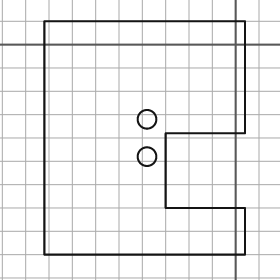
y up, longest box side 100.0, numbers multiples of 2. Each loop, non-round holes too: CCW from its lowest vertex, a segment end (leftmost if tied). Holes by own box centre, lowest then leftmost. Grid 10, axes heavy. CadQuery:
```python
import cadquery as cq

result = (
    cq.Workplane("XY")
    .moveTo(-82.0, -90.0)
    .lineTo(4.0, -90.0)
    .lineTo(4.0, -70.0)
    .lineTo(-30.0, -70.0)
    .lineTo(-30.0, -38.0)
    .lineTo(4.0, -38.0)
    .lineTo(4.0, 10.0)
    .lineTo(-82.0, 10.0)
    .close()
    .moveTo(-38.0, -48.0)
    .circle(4.0)
    .moveTo(-38.0, -32.0)
    .circle(4.0)
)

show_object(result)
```